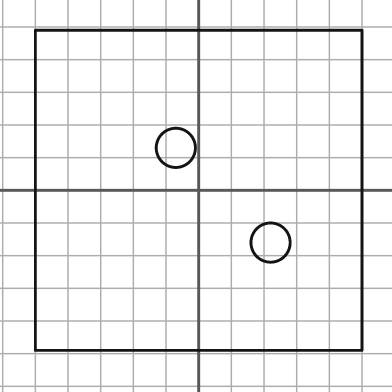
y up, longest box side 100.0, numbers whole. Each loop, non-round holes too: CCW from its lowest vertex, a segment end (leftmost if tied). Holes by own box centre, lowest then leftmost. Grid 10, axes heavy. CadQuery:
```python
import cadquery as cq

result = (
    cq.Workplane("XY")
    .moveTo(-50.0, -49.0)
    .lineTo(50.0, -49.0)
    .lineTo(50.0, 49.0)
    .lineTo(-50.0, 49.0)
    .close()
    .moveTo(22.0, -16.0)
    .circle(6.0)
    .moveTo(-7.0, 13.0)
    .circle(6.0)
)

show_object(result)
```